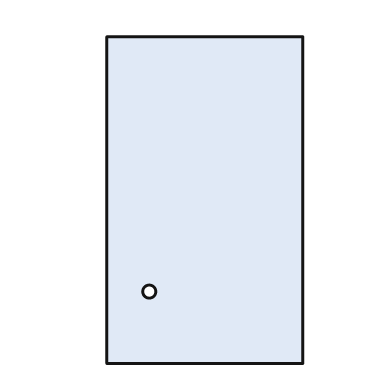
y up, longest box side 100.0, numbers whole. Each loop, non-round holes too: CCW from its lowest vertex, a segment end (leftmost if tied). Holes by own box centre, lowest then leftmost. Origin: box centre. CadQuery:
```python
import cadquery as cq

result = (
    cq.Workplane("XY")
    .moveTo(-30.0, -50.0)
    .lineTo(30.0, -50.0)
    .lineTo(30.0, 50.0)
    .lineTo(-30.0, 50.0)
    .close()
    .moveTo(-17.0, -28.0)
    .circle(2.0)
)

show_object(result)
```